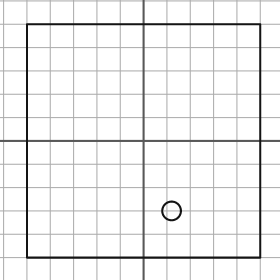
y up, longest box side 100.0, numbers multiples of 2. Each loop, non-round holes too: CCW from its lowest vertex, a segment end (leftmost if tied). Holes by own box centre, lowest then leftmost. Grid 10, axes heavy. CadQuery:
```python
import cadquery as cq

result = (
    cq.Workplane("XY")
    .moveTo(-50.0, -50.0)
    .lineTo(50.0, -50.0)
    .lineTo(50.0, 50.0)
    .lineTo(-50.0, 50.0)
    .close()
    .moveTo(12.0, -30.0)
    .circle(4.0)
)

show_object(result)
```